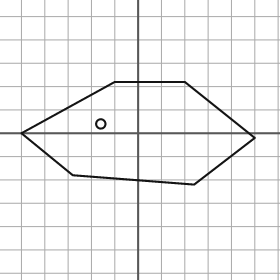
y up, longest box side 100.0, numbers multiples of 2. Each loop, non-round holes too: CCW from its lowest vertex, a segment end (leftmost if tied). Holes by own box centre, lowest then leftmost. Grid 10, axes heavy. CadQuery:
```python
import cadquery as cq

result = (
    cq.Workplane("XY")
    .moveTo(24.0, -22.0)
    .lineTo(50.0, -2.0)
    .lineTo(20.0, 22.0)
    .lineTo(-10.0, 22.0)
    .lineTo(-50.0, 0.0)
    .lineTo(-28.0, -18.0)
    .close()
    .moveTo(-16.0, 4.0)
    .circle(2.0)
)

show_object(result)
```